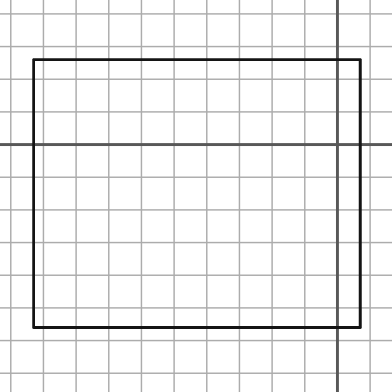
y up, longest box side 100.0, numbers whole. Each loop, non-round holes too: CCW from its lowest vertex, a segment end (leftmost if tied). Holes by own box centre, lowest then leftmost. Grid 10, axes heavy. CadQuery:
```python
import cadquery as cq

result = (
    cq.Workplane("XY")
    .moveTo(-93.0, -56.0)
    .lineTo(7.0, -56.0)
    .lineTo(7.0, 26.0)
    .lineTo(-93.0, 26.0)
    .close()
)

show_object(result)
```